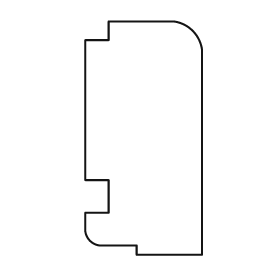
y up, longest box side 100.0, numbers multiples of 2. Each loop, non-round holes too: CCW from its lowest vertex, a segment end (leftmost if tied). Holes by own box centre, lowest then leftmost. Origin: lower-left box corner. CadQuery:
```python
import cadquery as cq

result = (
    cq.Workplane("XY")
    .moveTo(22.0, 0.0)
    .lineTo(50.0, 0.0)
    .lineTo(50.0, 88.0)
    .threePointArc((46.0, 96.0), (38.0, 100.0))
    .lineTo(10.0, 100.0)
    .lineTo(10.0, 92.0)
    .lineTo(0.0, 92.0)
    .lineTo(0.0, 32.0)
    .lineTo(10.0, 32.0)
    .lineTo(10.0, 18.0)
    .lineTo(0.0, 18.0)
    .lineTo(0.0, 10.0)
    .threePointArc((2.0, 6.0), (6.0, 4.0))
    .lineTo(22.0, 4.0)
    .close()
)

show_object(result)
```